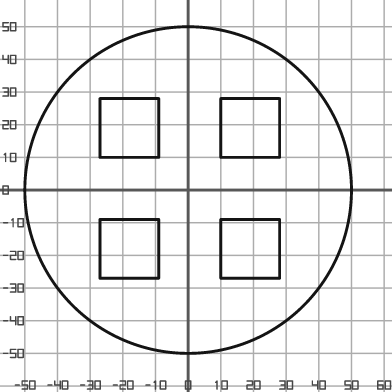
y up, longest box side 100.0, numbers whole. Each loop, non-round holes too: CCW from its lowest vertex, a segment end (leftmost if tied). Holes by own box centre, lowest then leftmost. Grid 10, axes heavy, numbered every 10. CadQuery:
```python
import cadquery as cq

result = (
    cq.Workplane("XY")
    .moveTo(0.0, 0.0)
    .circle(50.0)
    .moveTo(-27.0, -27.0)
    .lineTo(-9.0, -27.0)
    .lineTo(-9.0, -9.0)
    .lineTo(-27.0, -9.0)
    .close()
    .moveTo(10.0, -27.0)
    .lineTo(28.0, -27.0)
    .lineTo(28.0, -9.0)
    .lineTo(10.0, -9.0)
    .close()
    .moveTo(-27.0, 10.0)
    .lineTo(-9.0, 10.0)
    .lineTo(-9.0, 28.0)
    .lineTo(-27.0, 28.0)
    .close()
    .moveTo(10.0, 10.0)
    .lineTo(28.0, 10.0)
    .lineTo(28.0, 28.0)
    .lineTo(10.0, 28.0)
    .close()
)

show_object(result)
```